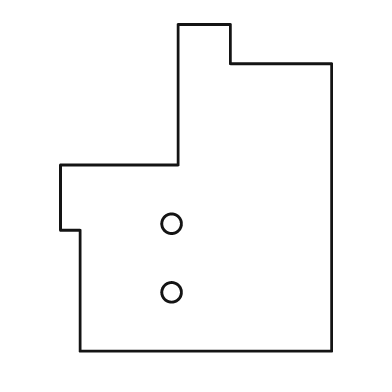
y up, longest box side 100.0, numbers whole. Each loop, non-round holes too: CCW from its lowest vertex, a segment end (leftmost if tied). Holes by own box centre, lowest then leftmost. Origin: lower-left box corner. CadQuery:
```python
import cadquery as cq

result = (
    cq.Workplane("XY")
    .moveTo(6.0, 0.0)
    .lineTo(83.0, 0.0)
    .lineTo(83.0, 88.0)
    .lineTo(52.0, 88.0)
    .lineTo(52.0, 100.0)
    .lineTo(36.0, 100.0)
    .lineTo(36.0, 57.0)
    .lineTo(0.0, 57.0)
    .lineTo(0.0, 37.0)
    .lineTo(6.0, 37.0)
    .close()
    .moveTo(34.0, 18.0)
    .circle(3.0)
    .moveTo(34.0, 39.0)
    .circle(3.0)
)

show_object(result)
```